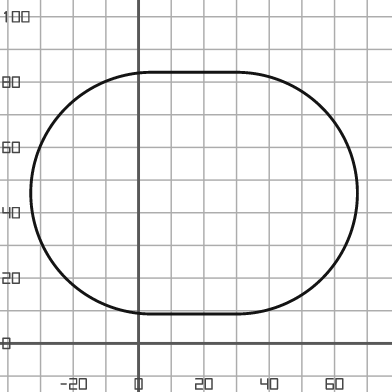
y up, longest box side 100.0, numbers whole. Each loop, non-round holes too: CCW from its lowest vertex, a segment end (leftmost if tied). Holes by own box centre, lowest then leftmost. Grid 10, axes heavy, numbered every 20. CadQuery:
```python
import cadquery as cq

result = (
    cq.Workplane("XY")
    .moveTo(4.0, 9.0)
    .lineTo(30.0, 9.0)
    .threePointArc((67.0, 46.0), (30.0, 83.0))
    .lineTo(4.0, 83.0)
    .threePointArc((-33.0, 46.0), (4.0, 9.0))
    .close()
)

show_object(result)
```